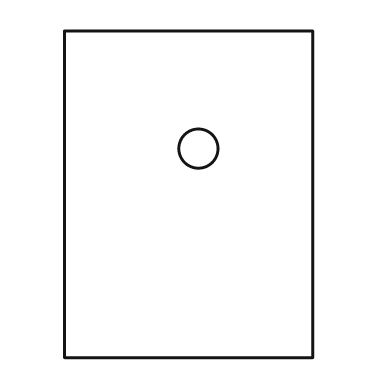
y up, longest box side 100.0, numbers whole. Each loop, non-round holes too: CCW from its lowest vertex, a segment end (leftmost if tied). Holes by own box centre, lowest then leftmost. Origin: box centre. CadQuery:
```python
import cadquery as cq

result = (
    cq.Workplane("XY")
    .moveTo(-38.0, -50.0)
    .lineTo(38.0, -50.0)
    .lineTo(38.0, 50.0)
    .lineTo(-38.0, 50.0)
    .close()
    .moveTo(3.0, 14.0)
    .circle(6.0)
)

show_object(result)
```